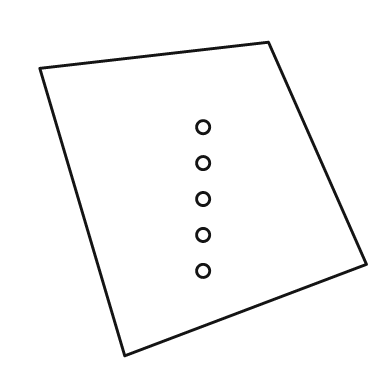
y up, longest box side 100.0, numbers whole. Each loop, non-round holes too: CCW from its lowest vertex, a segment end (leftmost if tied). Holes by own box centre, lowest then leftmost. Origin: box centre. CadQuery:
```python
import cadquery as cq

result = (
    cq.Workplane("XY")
    .moveTo(-24.0, -48.0)
    .lineTo(50.0, -20.0)
    .lineTo(20.0, 48.0)
    .lineTo(-50.0, 40.0)
    .close()
    .moveTo(0.0, -22.0)
    .circle(2.0)
    .moveTo(0.0, -11.0)
    .circle(2.0)
    .moveTo(0.0, 0.0)
    .circle(2.0)
    .moveTo(0.0, 11.0)
    .circle(2.0)
    .moveTo(0.0, 22.0)
    .circle(2.0)
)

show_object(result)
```